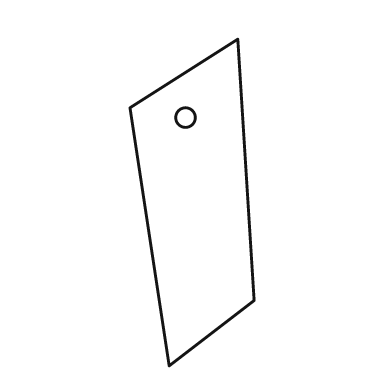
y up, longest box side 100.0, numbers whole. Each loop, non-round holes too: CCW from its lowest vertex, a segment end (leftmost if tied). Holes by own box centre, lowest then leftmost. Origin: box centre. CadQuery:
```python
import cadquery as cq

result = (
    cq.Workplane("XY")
    .moveTo(-7.0, -50.0)
    .lineTo(19.0, -30.0)
    .lineTo(14.0, 50.0)
    .lineTo(-19.0, 29.0)
    .close()
    .moveTo(-2.0, 26.0)
    .circle(3.0)
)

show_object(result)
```